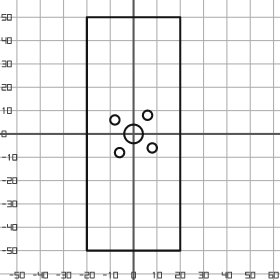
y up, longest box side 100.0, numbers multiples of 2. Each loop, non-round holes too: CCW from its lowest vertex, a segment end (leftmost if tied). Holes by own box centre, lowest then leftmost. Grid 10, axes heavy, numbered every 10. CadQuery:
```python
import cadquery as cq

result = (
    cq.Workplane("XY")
    .moveTo(-20.0, -50.0)
    .lineTo(20.0, -50.0)
    .lineTo(20.0, 50.0)
    .lineTo(-20.0, 50.0)
    .close()
    .moveTo(-6.0, -8.0)
    .circle(2.0)
    .moveTo(8.0, -6.0)
    .circle(2.0)
    .moveTo(0.0, 0.0)
    .circle(4.0)
    .moveTo(-8.0, 6.0)
    .circle(2.0)
    .moveTo(6.0, 8.0)
    .circle(2.0)
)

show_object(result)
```